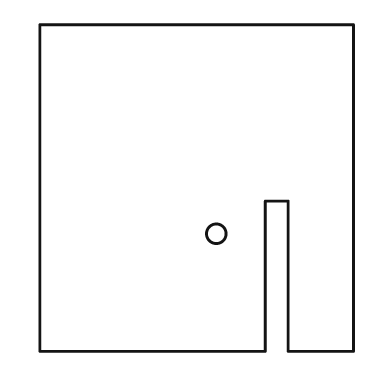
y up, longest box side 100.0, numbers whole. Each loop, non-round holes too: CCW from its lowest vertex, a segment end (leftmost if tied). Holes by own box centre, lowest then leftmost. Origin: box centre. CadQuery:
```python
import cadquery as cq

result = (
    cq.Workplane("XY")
    .moveTo(-48.0, -50.0)
    .lineTo(21.0, -50.0)
    .lineTo(21.0, -4.0)
    .lineTo(28.0, -4.0)
    .lineTo(28.0, -50.0)
    .lineTo(48.0, -50.0)
    .lineTo(48.0, 50.0)
    .lineTo(-48.0, 50.0)
    .close()
    .moveTo(6.0, -14.0)
    .circle(3.0)
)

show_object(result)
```